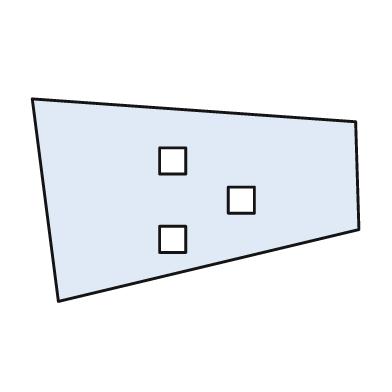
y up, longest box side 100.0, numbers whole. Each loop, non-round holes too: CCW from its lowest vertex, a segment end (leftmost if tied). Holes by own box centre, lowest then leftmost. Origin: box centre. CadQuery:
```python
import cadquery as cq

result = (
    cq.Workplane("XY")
    .moveTo(-42.0, -31.0)
    .lineTo(50.0, -9.0)
    .lineTo(49.0, 24.0)
    .lineTo(-50.0, 31.0)
    .close()
    .moveTo(-11.0, -16.0)
    .lineTo(-3.0, -16.0)
    .lineTo(-3.0, -8.0)
    .lineTo(-11.0, -8.0)
    .close()
    .moveTo(10.0, -4.0)
    .lineTo(18.0, -4.0)
    .lineTo(18.0, 4.0)
    .lineTo(10.0, 4.0)
    .close()
    .moveTo(-11.0, 8.0)
    .lineTo(-3.0, 8.0)
    .lineTo(-3.0, 16.0)
    .lineTo(-11.0, 16.0)
    .close()
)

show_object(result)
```